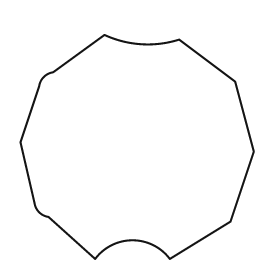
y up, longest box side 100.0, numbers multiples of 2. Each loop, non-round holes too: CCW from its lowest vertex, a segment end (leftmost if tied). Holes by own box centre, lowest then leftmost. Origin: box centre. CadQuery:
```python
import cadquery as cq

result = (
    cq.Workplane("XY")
    .moveTo(-18.0, -48.0)
    .threePointArc((-2.0, -40.0), (14.0, -48.0))
    .lineTo(40.0, -32.0)
    .lineTo(50.0, -2.0)
    .lineTo(42.0, 28.0)
    .lineTo(18.0, 46.0)
    .threePointArc((2.0, 44.0), (-14.0, 48.0))
    .lineTo(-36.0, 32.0)
    .threePointArc((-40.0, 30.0), (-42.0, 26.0))
    .lineTo(-50.0, 2.0)
    .lineTo(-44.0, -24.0)
    .threePointArc((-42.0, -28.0), (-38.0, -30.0))
    .close()
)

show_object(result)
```